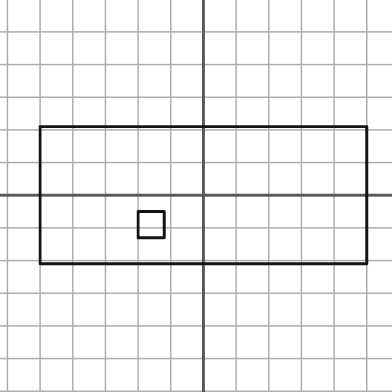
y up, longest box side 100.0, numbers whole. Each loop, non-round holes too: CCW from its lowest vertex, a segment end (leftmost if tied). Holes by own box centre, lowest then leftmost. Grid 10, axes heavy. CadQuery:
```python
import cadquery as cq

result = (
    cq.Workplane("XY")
    .moveTo(-50.0, -21.0)
    .lineTo(50.0, -21.0)
    .lineTo(50.0, 21.0)
    .lineTo(-50.0, 21.0)
    .close()
    .moveTo(-20.0, -13.0)
    .lineTo(-12.0, -13.0)
    .lineTo(-12.0, -5.0)
    .lineTo(-20.0, -5.0)
    .close()
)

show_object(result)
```